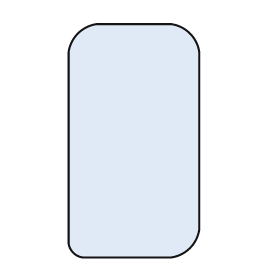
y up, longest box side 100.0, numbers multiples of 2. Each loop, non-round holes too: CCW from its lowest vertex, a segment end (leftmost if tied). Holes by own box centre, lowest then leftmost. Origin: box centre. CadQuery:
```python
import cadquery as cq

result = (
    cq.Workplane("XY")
    .moveTo(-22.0, -50.0)
    .lineTo(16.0, -50.0)
    .threePointArc((24.0, -46.0), (28.0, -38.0))
    .lineTo(28.0, 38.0)
    .threePointArc((24.0, 46.0), (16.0, 50.0))
    .lineTo(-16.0, 50.0)
    .threePointArc((-24.0, 46.0), (-28.0, 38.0))
    .lineTo(-28.0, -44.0)
    .threePointArc((-26.0, -48.0), (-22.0, -50.0))
    .close()
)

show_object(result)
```